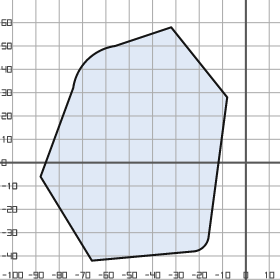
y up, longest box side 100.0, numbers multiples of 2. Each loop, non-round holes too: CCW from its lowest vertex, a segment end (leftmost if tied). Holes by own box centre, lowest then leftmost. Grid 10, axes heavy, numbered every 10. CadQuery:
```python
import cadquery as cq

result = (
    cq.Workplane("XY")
    .moveTo(-66.0, -42.0)
    .lineTo(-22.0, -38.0)
    .threePointArc((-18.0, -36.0), (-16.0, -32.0))
    .lineTo(-8.0, 28.0)
    .lineTo(-32.0, 58.0)
    .lineTo(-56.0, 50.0)
    .threePointArc((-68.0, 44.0), (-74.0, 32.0))
    .lineTo(-88.0, -6.0)
    .close()
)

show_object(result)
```